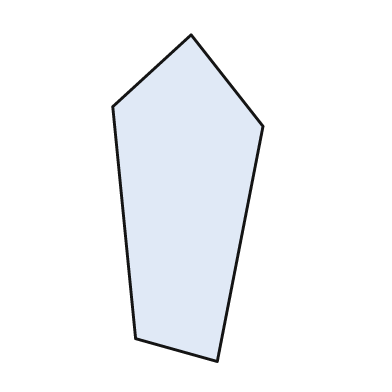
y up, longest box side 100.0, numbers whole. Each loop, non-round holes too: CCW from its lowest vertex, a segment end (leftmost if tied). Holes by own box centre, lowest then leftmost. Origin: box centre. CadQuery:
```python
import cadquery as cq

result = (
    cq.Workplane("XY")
    .moveTo(9.0, -50.0)
    .lineTo(23.0, 22.0)
    .lineTo(1.0, 50.0)
    .lineTo(-23.0, 28.0)
    .lineTo(-16.0, -43.0)
    .close()
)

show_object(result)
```